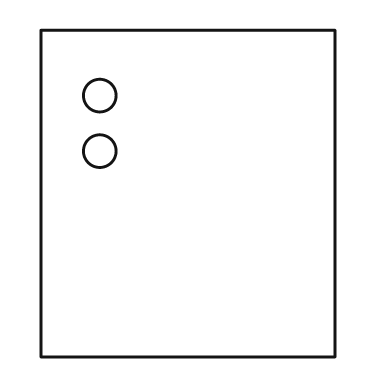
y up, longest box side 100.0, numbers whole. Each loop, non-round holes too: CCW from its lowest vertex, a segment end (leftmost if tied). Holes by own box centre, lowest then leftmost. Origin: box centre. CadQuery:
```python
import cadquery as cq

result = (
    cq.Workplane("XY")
    .moveTo(-45.0, -50.0)
    .lineTo(45.0, -50.0)
    .lineTo(45.0, 50.0)
    .lineTo(-45.0, 50.0)
    .close()
    .moveTo(-27.0, 13.0)
    .circle(5.0)
    .moveTo(-27.0, 30.0)
    .circle(5.0)
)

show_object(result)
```